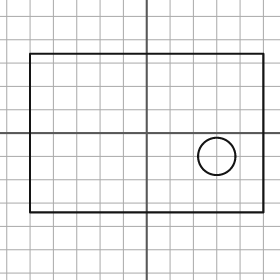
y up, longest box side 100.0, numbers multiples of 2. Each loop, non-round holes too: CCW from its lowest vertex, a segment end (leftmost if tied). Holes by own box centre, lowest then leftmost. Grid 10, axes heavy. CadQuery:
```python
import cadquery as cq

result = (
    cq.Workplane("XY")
    .moveTo(-50.0, -34.0)
    .lineTo(50.0, -34.0)
    .lineTo(50.0, 34.0)
    .lineTo(-50.0, 34.0)
    .close()
    .moveTo(30.0, -10.0)
    .circle(8.0)
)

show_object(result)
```